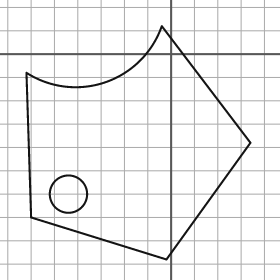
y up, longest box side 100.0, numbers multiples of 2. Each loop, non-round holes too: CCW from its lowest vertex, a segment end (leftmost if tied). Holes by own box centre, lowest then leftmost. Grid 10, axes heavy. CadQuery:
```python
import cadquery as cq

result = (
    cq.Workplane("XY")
    .moveTo(-2.0, -88.0)
    .lineTo(34.0, -38.0)
    .lineTo(-4.0, 12.0)
    .threePointArc((-28.0, -12.0), (-62.0, -8.0))
    .lineTo(-60.0, -70.0)
    .close()
    .moveTo(-44.0, -60.0)
    .circle(8.0)
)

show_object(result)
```